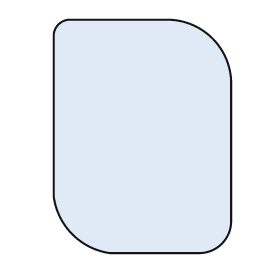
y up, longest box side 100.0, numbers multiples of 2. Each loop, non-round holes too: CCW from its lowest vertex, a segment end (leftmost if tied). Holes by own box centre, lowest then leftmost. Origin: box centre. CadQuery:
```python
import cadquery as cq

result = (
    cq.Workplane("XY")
    .moveTo(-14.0, -50.0)
    .lineTo(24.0, -50.0)
    .threePointArc((34.0, -46.0), (38.0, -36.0))
    .lineTo(38.0, 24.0)
    .threePointArc((30.0, 42.0), (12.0, 50.0))
    .lineTo(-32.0, 50.0)
    .threePointArc((-36.0, 48.0), (-38.0, 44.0))
    .lineTo(-38.0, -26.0)
    .threePointArc((-30.0, -42.0), (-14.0, -50.0))
    .close()
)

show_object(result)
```